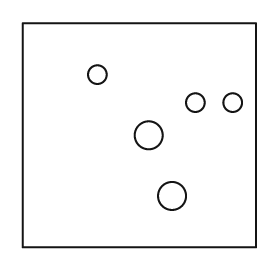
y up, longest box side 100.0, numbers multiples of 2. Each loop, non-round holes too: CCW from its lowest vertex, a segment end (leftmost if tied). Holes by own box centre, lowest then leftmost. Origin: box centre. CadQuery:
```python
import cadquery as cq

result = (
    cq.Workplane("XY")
    .moveTo(-50.0, -48.0)
    .lineTo(50.0, -48.0)
    .lineTo(50.0, 48.0)
    .lineTo(-50.0, 48.0)
    .close()
    .moveTo(14.0, -26.0)
    .circle(6.0)
    .moveTo(4.0, 0.0)
    .circle(6.0)
    .moveTo(24.0, 14.0)
    .circle(4.0)
    .moveTo(40.0, 14.0)
    .circle(4.0)
    .moveTo(-18.0, 26.0)
    .circle(4.0)
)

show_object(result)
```